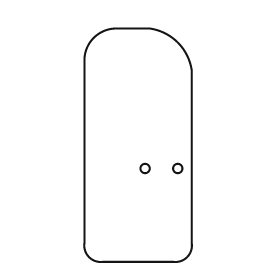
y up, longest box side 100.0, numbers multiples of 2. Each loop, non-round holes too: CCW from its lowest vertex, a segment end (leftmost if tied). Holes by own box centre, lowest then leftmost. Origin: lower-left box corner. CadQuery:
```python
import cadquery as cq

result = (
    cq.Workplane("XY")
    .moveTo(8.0, 0.0)
    .lineTo(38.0, 0.0)
    .threePointArc((44.0, 2.0), (46.0, 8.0))
    .lineTo(46.0, 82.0)
    .threePointArc((40.0, 94.0), (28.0, 100.0))
    .lineTo(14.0, 100.0)
    .threePointArc((4.0, 96.0), (0.0, 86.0))
    .lineTo(0.0, 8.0)
    .threePointArc((2.0, 2.0), (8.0, 0.0))
    .close()
    .moveTo(26.0, 40.0)
    .circle(2.0)
    .moveTo(40.0, 40.0)
    .circle(2.0)
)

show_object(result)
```